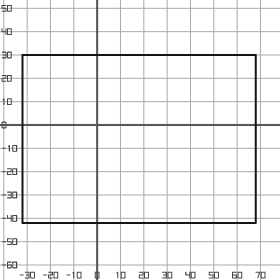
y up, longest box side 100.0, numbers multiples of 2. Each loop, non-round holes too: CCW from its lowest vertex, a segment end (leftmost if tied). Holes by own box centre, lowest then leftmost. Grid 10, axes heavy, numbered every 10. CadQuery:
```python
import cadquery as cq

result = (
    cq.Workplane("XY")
    .moveTo(-32.0, -42.0)
    .lineTo(68.0, -42.0)
    .lineTo(68.0, 30.0)
    .lineTo(-32.0, 30.0)
    .close()
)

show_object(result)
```